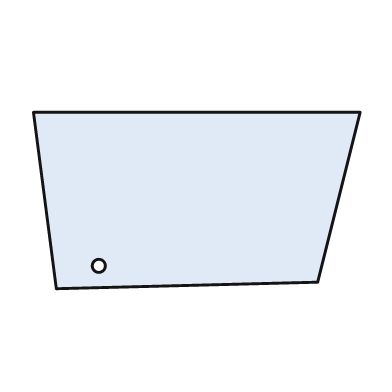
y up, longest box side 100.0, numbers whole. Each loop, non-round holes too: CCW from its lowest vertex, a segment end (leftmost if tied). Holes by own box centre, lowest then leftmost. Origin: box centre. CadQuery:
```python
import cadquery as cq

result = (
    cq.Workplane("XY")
    .moveTo(-43.0, -27.0)
    .lineTo(37.0, -25.0)
    .lineTo(50.0, 27.0)
    .lineTo(-50.0, 27.0)
    .close()
    .moveTo(-30.0, -20.0)
    .circle(2.0)
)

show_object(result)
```